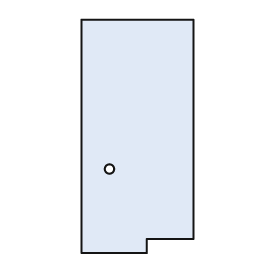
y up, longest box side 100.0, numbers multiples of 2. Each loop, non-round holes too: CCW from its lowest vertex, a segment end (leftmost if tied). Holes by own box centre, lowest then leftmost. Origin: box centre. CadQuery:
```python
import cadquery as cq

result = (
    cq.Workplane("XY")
    .moveTo(-24.0, -50.0)
    .lineTo(4.0, -50.0)
    .lineTo(4.0, -44.0)
    .lineTo(24.0, -44.0)
    .lineTo(24.0, 50.0)
    .lineTo(-24.0, 50.0)
    .close()
    .moveTo(-12.0, -14.0)
    .circle(2.0)
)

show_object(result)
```